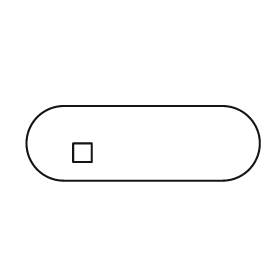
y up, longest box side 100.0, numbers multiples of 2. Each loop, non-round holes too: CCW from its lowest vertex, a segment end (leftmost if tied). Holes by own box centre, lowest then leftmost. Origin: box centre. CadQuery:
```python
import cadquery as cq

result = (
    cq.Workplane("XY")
    .moveTo(-34.0, -16.0)
    .lineTo(34.0, -16.0)
    .threePointArc((50.0, 0.0), (34.0, 16.0))
    .lineTo(-34.0, 16.0)
    .threePointArc((-50.0, 0.0), (-34.0, -16.0))
    .close()
    .moveTo(-30.0, -8.0)
    .lineTo(-22.0, -8.0)
    .lineTo(-22.0, 0.0)
    .lineTo(-30.0, 0.0)
    .close()
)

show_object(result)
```